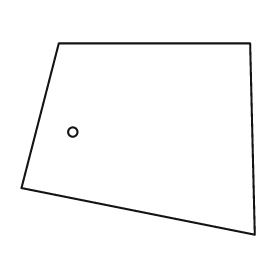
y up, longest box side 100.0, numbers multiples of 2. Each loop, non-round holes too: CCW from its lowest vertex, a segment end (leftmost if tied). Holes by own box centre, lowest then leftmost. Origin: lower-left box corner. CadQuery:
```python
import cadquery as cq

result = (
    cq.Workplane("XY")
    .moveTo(100.0, 0.0)
    .lineTo(98.0, 82.0)
    .lineTo(16.0, 82.0)
    .lineTo(0.0, 20.0)
    .close()
    .moveTo(22.0, 44.0)
    .circle(2.0)
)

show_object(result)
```